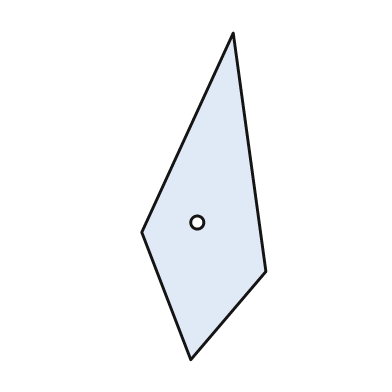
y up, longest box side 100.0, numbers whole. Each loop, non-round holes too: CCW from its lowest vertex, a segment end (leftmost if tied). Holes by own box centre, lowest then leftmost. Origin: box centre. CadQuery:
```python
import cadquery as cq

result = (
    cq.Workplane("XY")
    .moveTo(-4.0, -50.0)
    .lineTo(19.0, -23.0)
    .lineTo(9.0, 50.0)
    .lineTo(-19.0, -11.0)
    .close()
    .moveTo(-2.0, -8.0)
    .circle(2.0)
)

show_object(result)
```